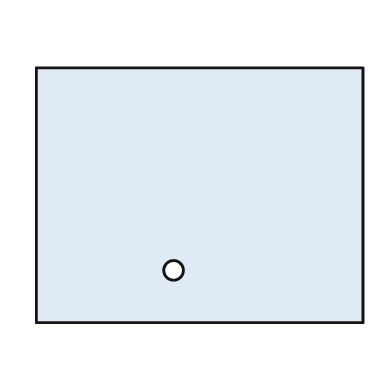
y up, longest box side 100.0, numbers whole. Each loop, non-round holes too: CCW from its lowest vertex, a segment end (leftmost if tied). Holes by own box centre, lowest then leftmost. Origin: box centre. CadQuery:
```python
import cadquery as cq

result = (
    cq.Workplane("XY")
    .moveTo(-50.0, -39.0)
    .lineTo(50.0, -39.0)
    .lineTo(50.0, 39.0)
    .lineTo(-50.0, 39.0)
    .close()
    .moveTo(-8.0, -23.0)
    .circle(3.0)
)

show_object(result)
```